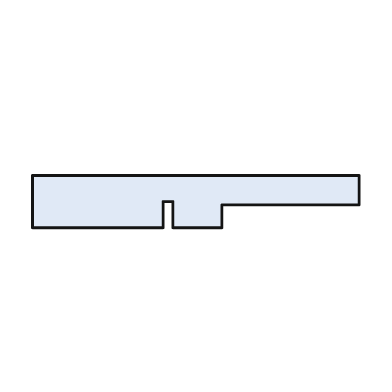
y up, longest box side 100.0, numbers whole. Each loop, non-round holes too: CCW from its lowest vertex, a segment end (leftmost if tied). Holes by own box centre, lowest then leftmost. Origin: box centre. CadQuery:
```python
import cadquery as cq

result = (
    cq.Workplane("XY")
    .moveTo(-50.0, -8.0)
    .lineTo(-10.0, -8.0)
    .lineTo(-10.0, 0.0)
    .lineTo(-7.0, 0.0)
    .lineTo(-7.0, -8.0)
    .lineTo(8.0, -8.0)
    .lineTo(8.0, -1.0)
    .lineTo(50.0, -1.0)
    .lineTo(50.0, 8.0)
    .lineTo(-50.0, 8.0)
    .close()
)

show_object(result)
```